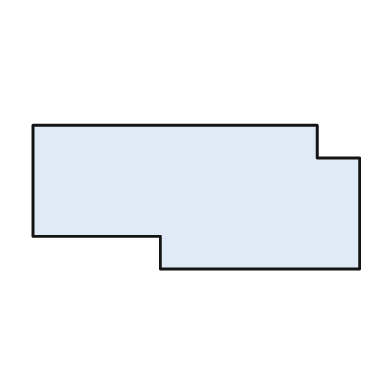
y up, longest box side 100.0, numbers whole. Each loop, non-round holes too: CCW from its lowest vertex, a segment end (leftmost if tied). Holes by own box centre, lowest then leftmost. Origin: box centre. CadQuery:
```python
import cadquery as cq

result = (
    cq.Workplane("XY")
    .moveTo(-11.0, -22.0)
    .lineTo(50.0, -22.0)
    .lineTo(50.0, 12.0)
    .lineTo(37.0, 12.0)
    .lineTo(37.0, 22.0)
    .lineTo(-50.0, 22.0)
    .lineTo(-50.0, -12.0)
    .lineTo(-11.0, -12.0)
    .close()
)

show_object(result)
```